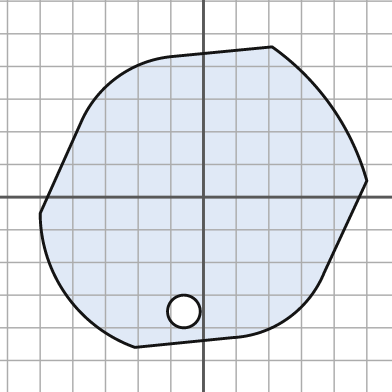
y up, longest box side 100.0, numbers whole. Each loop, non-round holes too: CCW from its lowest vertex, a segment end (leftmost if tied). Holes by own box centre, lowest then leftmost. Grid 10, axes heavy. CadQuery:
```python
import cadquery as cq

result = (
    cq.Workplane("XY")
    .moveTo(-21.0, -46.0)
    .lineTo(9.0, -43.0)
    .threePointArc((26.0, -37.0), (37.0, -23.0))
    .lineTo(50.0, 5.0)
    .threePointArc((39.0, 28.0), (21.0, 46.0))
    .lineTo(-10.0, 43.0)
    .threePointArc((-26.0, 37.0), (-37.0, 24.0))
    .lineTo(-50.0, -5.0)
    .threePointArc((-42.0, -30.0), (-21.0, -46.0))
    .close()
    .moveTo(-6.0, -35.0)
    .circle(5.0)
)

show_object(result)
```